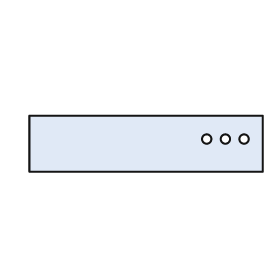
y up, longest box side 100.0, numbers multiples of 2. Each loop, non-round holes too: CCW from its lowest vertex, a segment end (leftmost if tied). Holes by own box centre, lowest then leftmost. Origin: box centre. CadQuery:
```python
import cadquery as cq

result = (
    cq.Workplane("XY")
    .moveTo(-50.0, -12.0)
    .lineTo(50.0, -12.0)
    .lineTo(50.0, 12.0)
    .lineTo(-50.0, 12.0)
    .close()
    .moveTo(26.0, 2.0)
    .circle(2.0)
    .moveTo(34.0, 2.0)
    .circle(2.0)
    .moveTo(42.0, 2.0)
    .circle(2.0)
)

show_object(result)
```